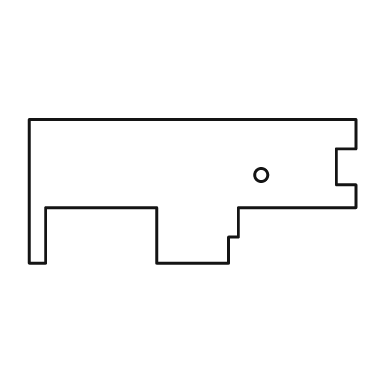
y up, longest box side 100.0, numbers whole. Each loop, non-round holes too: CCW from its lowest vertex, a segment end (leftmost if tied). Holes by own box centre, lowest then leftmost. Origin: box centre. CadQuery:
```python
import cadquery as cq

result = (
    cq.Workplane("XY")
    .moveTo(-50.0, -22.0)
    .lineTo(-45.0, -22.0)
    .lineTo(-45.0, -5.0)
    .lineTo(-11.0, -5.0)
    .lineTo(-11.0, -22.0)
    .lineTo(11.0, -22.0)
    .lineTo(11.0, -14.0)
    .lineTo(14.0, -14.0)
    .lineTo(14.0, -5.0)
    .lineTo(50.0, -5.0)
    .lineTo(50.0, 2.0)
    .lineTo(44.0, 2.0)
    .lineTo(44.0, 13.0)
    .lineTo(50.0, 13.0)
    .lineTo(50.0, 22.0)
    .lineTo(-50.0, 22.0)
    .close()
    .moveTo(21.0, 5.0)
    .circle(2.0)
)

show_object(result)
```